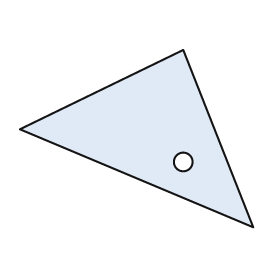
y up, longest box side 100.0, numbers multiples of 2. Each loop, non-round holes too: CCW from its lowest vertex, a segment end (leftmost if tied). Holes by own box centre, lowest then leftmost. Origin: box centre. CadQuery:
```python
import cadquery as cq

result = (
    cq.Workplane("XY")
    .moveTo(50.0, -38.0)
    .lineTo(20.0, 38.0)
    .lineTo(-50.0, 4.0)
    .close()
    .moveTo(20.0, -10.0)
    .circle(4.0)
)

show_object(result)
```